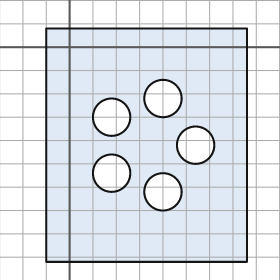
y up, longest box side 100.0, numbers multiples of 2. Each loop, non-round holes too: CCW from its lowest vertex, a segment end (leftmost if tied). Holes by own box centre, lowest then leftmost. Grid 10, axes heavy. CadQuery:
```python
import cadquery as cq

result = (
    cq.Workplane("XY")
    .moveTo(-10.0, -92.0)
    .lineTo(76.0, -92.0)
    .lineTo(76.0, 8.0)
    .lineTo(-10.0, 8.0)
    .close()
    .moveTo(40.0, -62.0)
    .circle(8.0)
    .moveTo(18.0, -54.0)
    .circle(8.0)
    .moveTo(54.0, -42.0)
    .circle(8.0)
    .moveTo(18.0, -30.0)
    .circle(8.0)
    .moveTo(40.0, -22.0)
    .circle(8.0)
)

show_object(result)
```